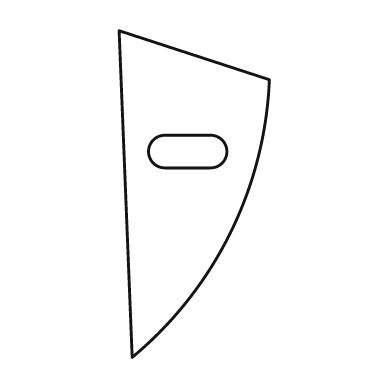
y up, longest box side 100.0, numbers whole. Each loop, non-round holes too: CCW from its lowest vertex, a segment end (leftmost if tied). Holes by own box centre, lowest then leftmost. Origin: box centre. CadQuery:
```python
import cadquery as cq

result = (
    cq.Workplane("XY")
    .moveTo(-19.0, -50.0)
    .threePointArc((11.0, -12.0), (23.0, 35.0))
    .lineTo(-23.0, 50.0)
    .close()
    .moveTo(-9.0, 8.0)
    .lineTo(5.0, 8.0)
    .threePointArc((10.0, 13.0), (5.0, 18.0))
    .lineTo(-9.0, 18.0)
    .threePointArc((-14.0, 13.0), (-9.0, 8.0))
    .close()
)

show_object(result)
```